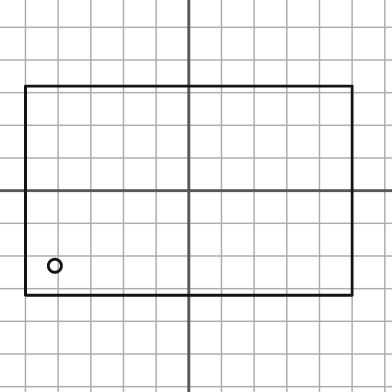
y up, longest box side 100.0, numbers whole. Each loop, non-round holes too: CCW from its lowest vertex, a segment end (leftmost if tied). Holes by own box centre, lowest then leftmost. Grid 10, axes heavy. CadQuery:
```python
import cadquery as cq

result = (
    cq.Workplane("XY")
    .moveTo(-50.0, -32.0)
    .lineTo(50.0, -32.0)
    .lineTo(50.0, 32.0)
    .lineTo(-50.0, 32.0)
    .close()
    .moveTo(-41.0, -23.0)
    .circle(2.0)
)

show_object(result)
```